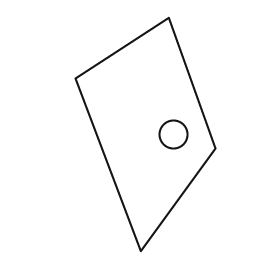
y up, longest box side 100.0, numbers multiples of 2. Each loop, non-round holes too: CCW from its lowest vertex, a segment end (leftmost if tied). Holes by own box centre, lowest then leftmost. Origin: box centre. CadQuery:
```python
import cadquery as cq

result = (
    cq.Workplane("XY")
    .moveTo(-2.0, -50.0)
    .lineTo(30.0, -6.0)
    .lineTo(10.0, 50.0)
    .lineTo(-30.0, 24.0)
    .close()
    .moveTo(12.0, 0.0)
    .circle(6.0)
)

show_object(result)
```